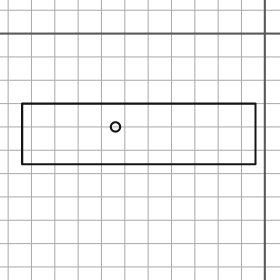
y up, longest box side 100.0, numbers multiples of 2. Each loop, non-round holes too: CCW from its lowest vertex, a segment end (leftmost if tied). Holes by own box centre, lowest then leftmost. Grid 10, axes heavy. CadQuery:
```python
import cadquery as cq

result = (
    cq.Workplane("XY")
    .moveTo(-104.0, -56.0)
    .lineTo(-4.0, -56.0)
    .lineTo(-4.0, -30.0)
    .lineTo(-104.0, -30.0)
    .close()
    .moveTo(-64.0, -40.0)
    .circle(2.0)
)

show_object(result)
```